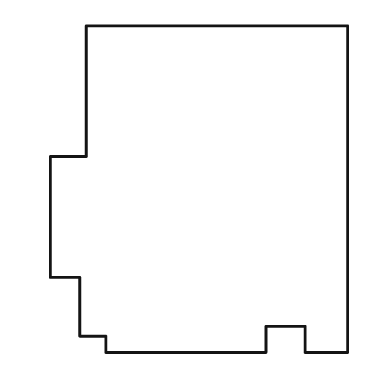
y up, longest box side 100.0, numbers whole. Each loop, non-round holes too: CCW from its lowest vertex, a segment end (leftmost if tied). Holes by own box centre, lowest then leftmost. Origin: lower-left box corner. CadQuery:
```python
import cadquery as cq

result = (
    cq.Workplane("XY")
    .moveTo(17.0, 0.0)
    .lineTo(66.0, 0.0)
    .lineTo(66.0, 8.0)
    .lineTo(78.0, 8.0)
    .lineTo(78.0, 0.0)
    .lineTo(91.0, 0.0)
    .lineTo(91.0, 100.0)
    .lineTo(11.0, 100.0)
    .lineTo(11.0, 60.0)
    .lineTo(0.0, 60.0)
    .lineTo(0.0, 23.0)
    .lineTo(9.0, 23.0)
    .lineTo(9.0, 5.0)
    .lineTo(17.0, 5.0)
    .close()
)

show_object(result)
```